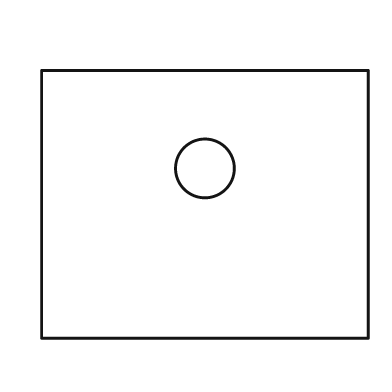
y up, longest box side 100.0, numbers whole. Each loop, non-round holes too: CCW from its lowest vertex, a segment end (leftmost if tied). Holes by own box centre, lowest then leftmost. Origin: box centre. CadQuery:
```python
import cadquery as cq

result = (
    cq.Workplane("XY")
    .moveTo(-50.0, -41.0)
    .lineTo(50.0, -41.0)
    .lineTo(50.0, 41.0)
    .lineTo(-50.0, 41.0)
    .close()
    .moveTo(0.0, 11.0)
    .circle(9.0)
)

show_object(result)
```